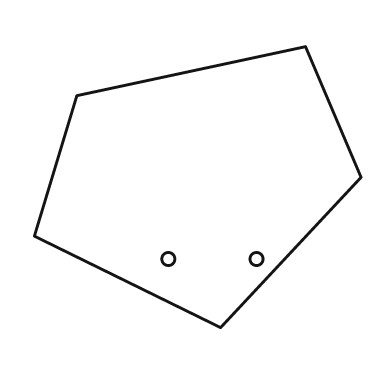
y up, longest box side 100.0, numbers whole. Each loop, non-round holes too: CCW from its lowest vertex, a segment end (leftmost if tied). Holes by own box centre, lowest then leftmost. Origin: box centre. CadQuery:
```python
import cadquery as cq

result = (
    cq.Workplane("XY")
    .moveTo(7.0, -43.0)
    .lineTo(50.0, 3.0)
    .lineTo(33.0, 43.0)
    .lineTo(-37.0, 28.0)
    .lineTo(-50.0, -15.0)
    .close()
    .moveTo(-9.0, -22.0)
    .circle(2.0)
    .moveTo(18.0, -22.0)
    .circle(2.0)
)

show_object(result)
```